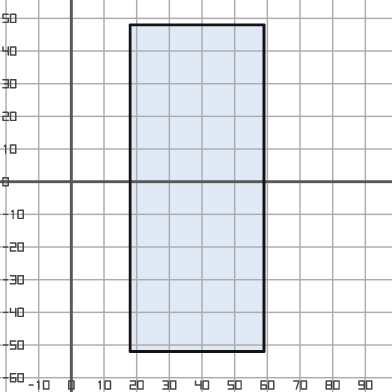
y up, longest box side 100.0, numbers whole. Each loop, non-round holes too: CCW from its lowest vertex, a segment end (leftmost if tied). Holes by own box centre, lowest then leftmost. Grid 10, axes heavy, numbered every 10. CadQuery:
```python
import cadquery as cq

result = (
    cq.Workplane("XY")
    .moveTo(18.0, -52.0)
    .lineTo(59.0, -52.0)
    .lineTo(59.0, 48.0)
    .lineTo(18.0, 48.0)
    .close()
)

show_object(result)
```